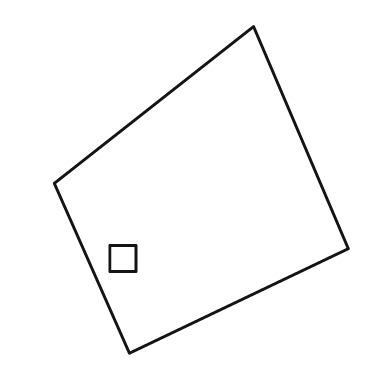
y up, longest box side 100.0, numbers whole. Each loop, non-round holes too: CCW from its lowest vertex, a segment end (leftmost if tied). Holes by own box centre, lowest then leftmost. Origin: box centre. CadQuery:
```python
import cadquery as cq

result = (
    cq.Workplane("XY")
    .moveTo(-22.0, -50.0)
    .lineTo(45.0, -18.0)
    .lineTo(16.0, 50.0)
    .lineTo(-45.0, 2.0)
    .close()
    .moveTo(-28.0, -25.0)
    .lineTo(-20.0, -25.0)
    .lineTo(-20.0, -17.0)
    .lineTo(-28.0, -17.0)
    .close()
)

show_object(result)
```